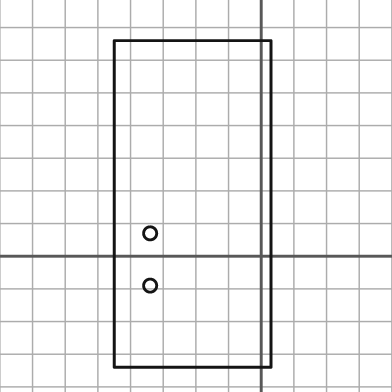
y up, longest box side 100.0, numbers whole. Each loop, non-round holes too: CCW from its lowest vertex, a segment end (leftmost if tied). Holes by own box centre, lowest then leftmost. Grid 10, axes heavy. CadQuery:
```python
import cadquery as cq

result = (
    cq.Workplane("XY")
    .moveTo(-45.0, -34.0)
    .lineTo(3.0, -34.0)
    .lineTo(3.0, 66.0)
    .lineTo(-45.0, 66.0)
    .close()
    .moveTo(-34.0, -9.0)
    .circle(2.0)
    .moveTo(-34.0, 7.0)
    .circle(2.0)
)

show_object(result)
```